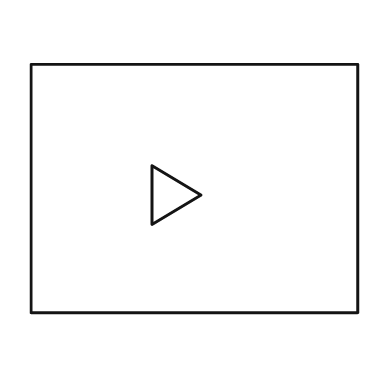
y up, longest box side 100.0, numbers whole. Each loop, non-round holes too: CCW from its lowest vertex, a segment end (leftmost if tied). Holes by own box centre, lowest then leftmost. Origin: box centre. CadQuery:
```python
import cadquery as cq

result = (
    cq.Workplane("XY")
    .moveTo(-50.0, -38.0)
    .lineTo(50.0, -38.0)
    .lineTo(50.0, 38.0)
    .lineTo(-50.0, 38.0)
    .close()
    .moveTo(-13.0, -11.0)
    .lineTo(2.0, -2.0)
    .lineTo(-13.0, 7.0)
    .close()
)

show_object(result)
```